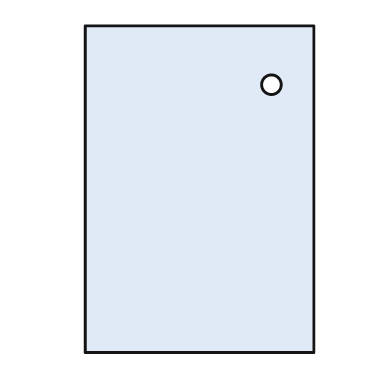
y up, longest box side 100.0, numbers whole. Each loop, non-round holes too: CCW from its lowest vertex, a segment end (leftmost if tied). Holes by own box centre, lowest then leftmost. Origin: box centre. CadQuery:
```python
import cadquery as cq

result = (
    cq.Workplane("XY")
    .moveTo(-35.0, -50.0)
    .lineTo(35.0, -50.0)
    .lineTo(35.0, 50.0)
    .lineTo(-35.0, 50.0)
    .close()
    .moveTo(22.0, 32.0)
    .circle(3.0)
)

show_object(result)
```